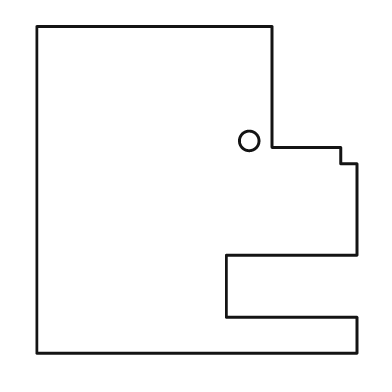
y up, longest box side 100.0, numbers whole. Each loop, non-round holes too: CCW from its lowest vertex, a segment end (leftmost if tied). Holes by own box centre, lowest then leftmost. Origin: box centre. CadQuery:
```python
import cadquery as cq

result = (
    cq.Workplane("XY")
    .moveTo(-49.0, -50.0)
    .lineTo(49.0, -50.0)
    .lineTo(49.0, -39.0)
    .lineTo(9.0, -39.0)
    .lineTo(9.0, -20.0)
    .lineTo(49.0, -20.0)
    .lineTo(49.0, 8.0)
    .lineTo(44.0, 8.0)
    .lineTo(44.0, 13.0)
    .lineTo(23.0, 13.0)
    .lineTo(23.0, 50.0)
    .lineTo(-49.0, 50.0)
    .close()
    .moveTo(16.0, 15.0)
    .circle(3.0)
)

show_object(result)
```